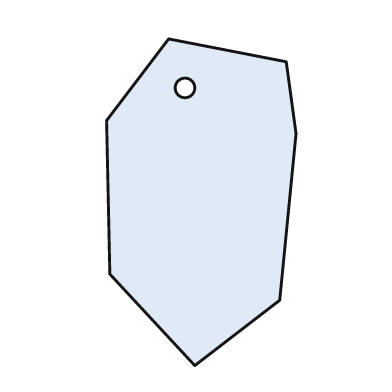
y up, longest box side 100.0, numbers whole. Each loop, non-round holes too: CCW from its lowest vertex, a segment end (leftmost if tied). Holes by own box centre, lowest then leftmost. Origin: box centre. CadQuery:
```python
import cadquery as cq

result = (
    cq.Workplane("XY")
    .moveTo(-2.0, -50.0)
    .lineTo(24.0, -30.0)
    .lineTo(29.0, 21.0)
    .lineTo(26.0, 43.0)
    .lineTo(-10.0, 50.0)
    .lineTo(-29.0, 25.0)
    .lineTo(-28.0, -22.0)
    .close()
    .moveTo(-5.0, 35.0)
    .circle(3.0)
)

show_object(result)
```